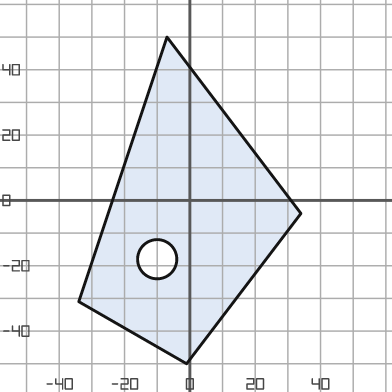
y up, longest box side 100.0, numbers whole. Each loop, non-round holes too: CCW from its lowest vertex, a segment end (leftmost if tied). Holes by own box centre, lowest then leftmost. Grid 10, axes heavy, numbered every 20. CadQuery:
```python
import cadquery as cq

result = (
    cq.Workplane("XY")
    .moveTo(-1.0, -50.0)
    .lineTo(34.0, -4.0)
    .lineTo(-7.0, 50.0)
    .lineTo(-34.0, -31.0)
    .close()
    .moveTo(-10.0, -18.0)
    .circle(6.0)
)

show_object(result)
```